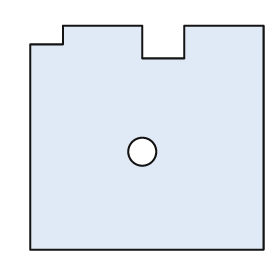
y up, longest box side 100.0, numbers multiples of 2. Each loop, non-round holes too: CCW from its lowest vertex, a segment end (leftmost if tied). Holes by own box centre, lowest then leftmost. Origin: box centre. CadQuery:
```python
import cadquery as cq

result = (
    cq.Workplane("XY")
    .moveTo(-50.0, -48.0)
    .lineTo(50.0, -48.0)
    .lineTo(50.0, 48.0)
    .lineTo(16.0, 48.0)
    .lineTo(16.0, 34.0)
    .lineTo(-2.0, 34.0)
    .lineTo(-2.0, 48.0)
    .lineTo(-36.0, 48.0)
    .lineTo(-36.0, 40.0)
    .lineTo(-50.0, 40.0)
    .close()
    .moveTo(-2.0, -6.0)
    .circle(6.0)
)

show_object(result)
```